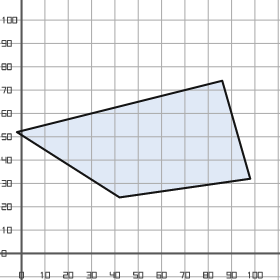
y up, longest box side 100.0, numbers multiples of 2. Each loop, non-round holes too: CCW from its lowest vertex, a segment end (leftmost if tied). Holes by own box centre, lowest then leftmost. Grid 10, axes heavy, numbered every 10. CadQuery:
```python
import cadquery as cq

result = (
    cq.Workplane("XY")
    .moveTo(42.0, 24.0)
    .lineTo(98.0, 32.0)
    .lineTo(86.0, 74.0)
    .lineTo(-2.0, 52.0)
    .close()
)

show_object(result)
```